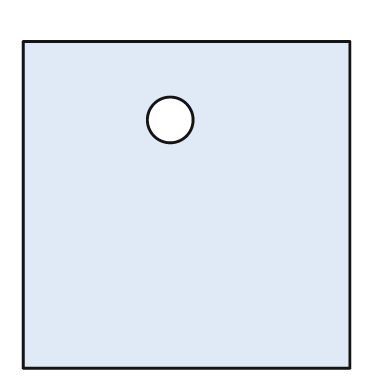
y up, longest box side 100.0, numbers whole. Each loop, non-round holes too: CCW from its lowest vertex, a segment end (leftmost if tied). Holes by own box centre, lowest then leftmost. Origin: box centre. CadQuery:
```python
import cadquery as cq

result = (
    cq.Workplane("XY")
    .moveTo(-50.0, -50.0)
    .lineTo(50.0, -50.0)
    .lineTo(50.0, 50.0)
    .lineTo(-50.0, 50.0)
    .close()
    .moveTo(-5.0, 26.0)
    .circle(7.0)
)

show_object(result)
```